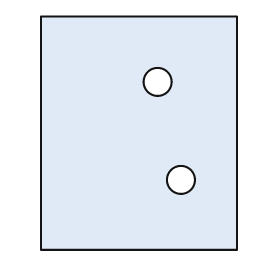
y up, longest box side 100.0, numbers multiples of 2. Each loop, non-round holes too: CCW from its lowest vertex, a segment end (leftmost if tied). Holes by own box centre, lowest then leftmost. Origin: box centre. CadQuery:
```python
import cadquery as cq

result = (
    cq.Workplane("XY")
    .moveTo(-42.0, -50.0)
    .lineTo(42.0, -50.0)
    .lineTo(42.0, 50.0)
    .lineTo(-42.0, 50.0)
    .close()
    .moveTo(18.0, -20.0)
    .circle(6.0)
    .moveTo(8.0, 22.0)
    .circle(6.0)
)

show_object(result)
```